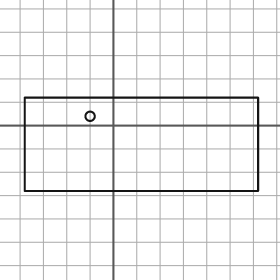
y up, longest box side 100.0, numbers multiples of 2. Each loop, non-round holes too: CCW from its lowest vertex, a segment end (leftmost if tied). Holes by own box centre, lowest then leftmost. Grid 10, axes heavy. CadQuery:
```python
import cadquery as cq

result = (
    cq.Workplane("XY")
    .moveTo(-38.0, -28.0)
    .lineTo(62.0, -28.0)
    .lineTo(62.0, 12.0)
    .lineTo(-38.0, 12.0)
    .close()
    .moveTo(-10.0, 4.0)
    .circle(2.0)
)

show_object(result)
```